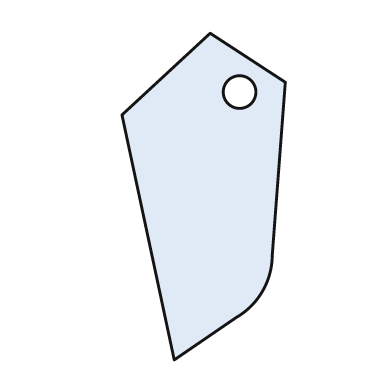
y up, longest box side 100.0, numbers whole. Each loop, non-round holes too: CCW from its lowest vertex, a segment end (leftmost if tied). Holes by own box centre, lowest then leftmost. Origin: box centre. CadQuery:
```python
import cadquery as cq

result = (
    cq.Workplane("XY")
    .moveTo(-9.0, -50.0)
    .lineTo(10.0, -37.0)
    .threePointArc((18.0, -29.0), (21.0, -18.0))
    .lineTo(25.0, 35.0)
    .lineTo(2.0, 50.0)
    .lineTo(-25.0, 25.0)
    .close()
    .moveTo(11.0, 32.0)
    .circle(5.0)
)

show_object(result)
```